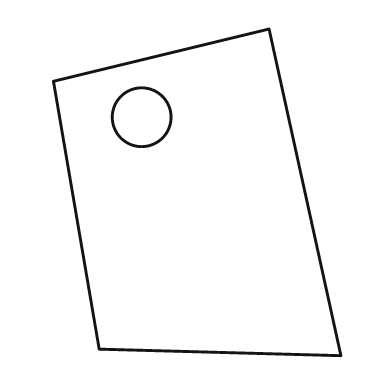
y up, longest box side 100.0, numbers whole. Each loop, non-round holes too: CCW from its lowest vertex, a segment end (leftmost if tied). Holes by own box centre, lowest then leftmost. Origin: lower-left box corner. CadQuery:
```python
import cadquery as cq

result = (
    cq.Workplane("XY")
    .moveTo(88.0, 0.0)
    .lineTo(66.0, 100.0)
    .lineTo(0.0, 84.0)
    .lineTo(14.0, 2.0)
    .close()
    .moveTo(27.0, 73.0)
    .circle(9.0)
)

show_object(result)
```